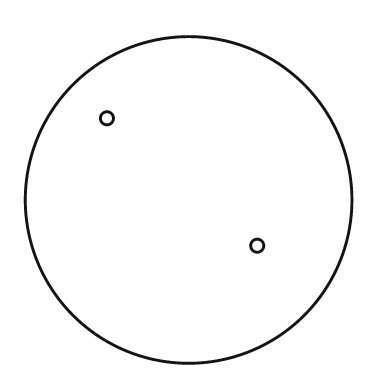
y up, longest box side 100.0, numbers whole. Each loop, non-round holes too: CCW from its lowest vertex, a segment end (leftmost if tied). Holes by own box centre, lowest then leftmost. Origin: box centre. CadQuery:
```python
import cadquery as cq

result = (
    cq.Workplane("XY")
    .moveTo(0.0, 0.0)
    .circle(50.0)
    .moveTo(21.0, -14.0)
    .circle(2.0)
    .moveTo(-25.0, 25.0)
    .circle(2.0)
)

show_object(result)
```